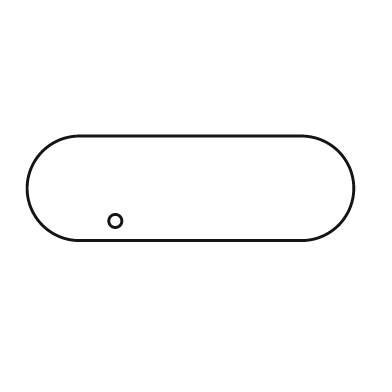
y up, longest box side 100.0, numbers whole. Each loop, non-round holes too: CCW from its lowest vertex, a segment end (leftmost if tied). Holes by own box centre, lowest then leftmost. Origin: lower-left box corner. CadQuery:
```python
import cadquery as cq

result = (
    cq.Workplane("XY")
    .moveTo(16.0, 0.0)
    .lineTo(84.0, 0.0)
    .threePointArc((100.0, 16.0), (84.0, 32.0))
    .lineTo(16.0, 32.0)
    .threePointArc((0.0, 16.0), (16.0, 0.0))
    .close()
    .moveTo(27.0, 6.0)
    .circle(2.0)
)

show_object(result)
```